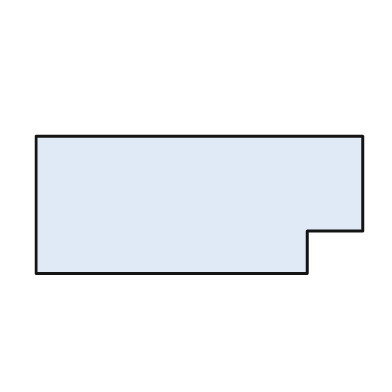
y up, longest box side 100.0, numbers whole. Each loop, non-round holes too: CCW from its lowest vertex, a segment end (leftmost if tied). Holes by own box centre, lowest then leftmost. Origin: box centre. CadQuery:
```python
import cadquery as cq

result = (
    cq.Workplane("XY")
    .moveTo(-50.0, -21.0)
    .lineTo(33.0, -21.0)
    .lineTo(33.0, -8.0)
    .lineTo(50.0, -8.0)
    .lineTo(50.0, 21.0)
    .lineTo(-50.0, 21.0)
    .close()
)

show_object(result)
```